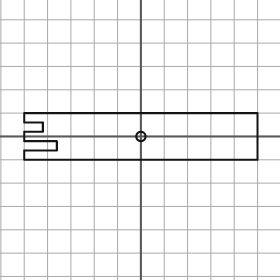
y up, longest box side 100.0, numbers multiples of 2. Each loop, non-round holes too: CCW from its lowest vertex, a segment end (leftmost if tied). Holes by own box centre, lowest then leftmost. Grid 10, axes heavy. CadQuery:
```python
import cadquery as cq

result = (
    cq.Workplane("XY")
    .moveTo(-50.0, -10.0)
    .lineTo(50.0, -10.0)
    .lineTo(50.0, 10.0)
    .lineTo(-50.0, 10.0)
    .lineTo(-50.0, 6.0)
    .lineTo(-42.0, 6.0)
    .lineTo(-42.0, 2.0)
    .lineTo(-50.0, 2.0)
    .lineTo(-50.0, -2.0)
    .lineTo(-36.0, -2.0)
    .lineTo(-36.0, -6.0)
    .lineTo(-50.0, -6.0)
    .close()
    .moveTo(0.0, 0.0)
    .circle(2.0)
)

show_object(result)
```